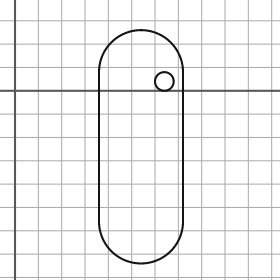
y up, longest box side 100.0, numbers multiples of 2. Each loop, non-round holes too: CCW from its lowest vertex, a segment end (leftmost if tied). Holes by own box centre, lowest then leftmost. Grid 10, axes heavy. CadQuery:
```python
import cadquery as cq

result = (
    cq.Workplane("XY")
    .moveTo(36.0, -56.0)
    .threePointArc((54.0, -74.0), (72.0, -56.0))
    .lineTo(72.0, 8.0)
    .threePointArc((54.0, 26.0), (36.0, 8.0))
    .close()
    .moveTo(64.0, 4.0)
    .circle(4.0)
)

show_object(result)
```